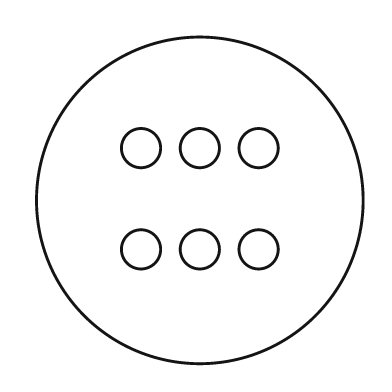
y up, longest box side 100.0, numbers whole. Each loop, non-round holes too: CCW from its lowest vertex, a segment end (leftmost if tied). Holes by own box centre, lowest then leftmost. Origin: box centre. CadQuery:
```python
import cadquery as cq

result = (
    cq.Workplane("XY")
    .moveTo(0.0, 0.0)
    .circle(50.0)
    .moveTo(-18.0, -15.0)
    .circle(6.0)
    .moveTo(0.0, -15.0)
    .circle(6.0)
    .moveTo(18.0, -15.0)
    .circle(6.0)
    .moveTo(-18.0, 16.0)
    .circle(6.0)
    .moveTo(0.0, 16.0)
    .circle(6.0)
    .moveTo(18.0, 16.0)
    .circle(6.0)
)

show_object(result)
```